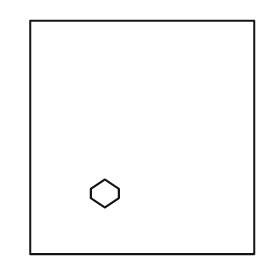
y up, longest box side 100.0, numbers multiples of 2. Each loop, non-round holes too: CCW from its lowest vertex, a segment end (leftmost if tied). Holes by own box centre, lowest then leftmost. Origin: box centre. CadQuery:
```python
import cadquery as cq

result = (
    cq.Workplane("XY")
    .moveTo(-48.0, -50.0)
    .lineTo(48.0, -50.0)
    .lineTo(48.0, 50.0)
    .lineTo(-48.0, 50.0)
    .close()
    .moveTo(-16.0, -30.0)
    .lineTo(-10.0, -26.0)
    .lineTo(-10.0, -22.0)
    .lineTo(-16.0, -18.0)
    .lineTo(-22.0, -22.0)
    .lineTo(-22.0, -26.0)
    .close()
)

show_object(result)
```